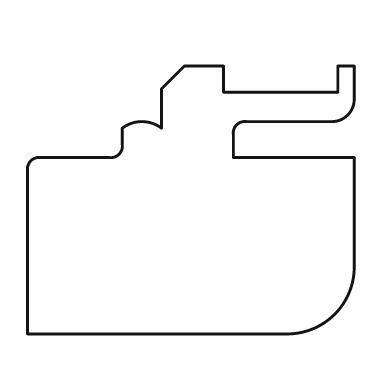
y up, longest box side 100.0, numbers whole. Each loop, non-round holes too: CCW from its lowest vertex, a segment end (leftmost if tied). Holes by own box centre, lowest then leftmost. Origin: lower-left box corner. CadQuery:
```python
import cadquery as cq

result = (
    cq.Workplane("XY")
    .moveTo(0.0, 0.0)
    .lineTo(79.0, 0.0)
    .threePointArc((94.0, 6.0), (100.0, 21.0))
    .lineTo(100.0, 54.0)
    .lineTo(63.0, 54.0)
    .lineTo(63.0, 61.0)
    .threePointArc((64.0, 64.0), (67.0, 65.0))
    .lineTo(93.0, 65.0)
    .threePointArc((98.0, 67.0), (100.0, 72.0))
    .lineTo(100.0, 82.0)
    .lineTo(95.0, 82.0)
    .lineTo(95.0, 74.0)
    .lineTo(60.0, 74.0)
    .lineTo(60.0, 82.0)
    .lineTo(48.0, 82.0)
    .lineTo(41.0, 75.0)
    .lineTo(41.0, 63.0)
    .threePointArc((35.0, 65.0), (29.0, 63.0))
    .lineTo(29.0, 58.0)
    .threePointArc((28.0, 55.0), (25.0, 54.0))
    .lineTo(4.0, 54.0)
    .threePointArc((1.0, 53.0), (0.0, 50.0))
    .close()
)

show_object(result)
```